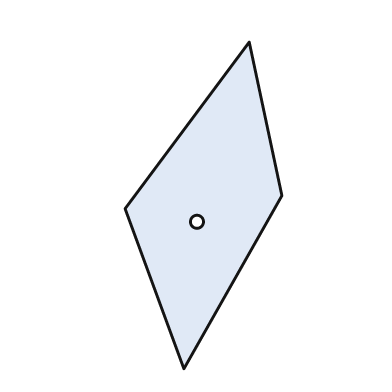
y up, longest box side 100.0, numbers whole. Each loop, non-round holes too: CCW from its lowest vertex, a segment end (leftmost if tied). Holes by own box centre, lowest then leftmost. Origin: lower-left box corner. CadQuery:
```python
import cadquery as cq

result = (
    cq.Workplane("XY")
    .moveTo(18.0, 0.0)
    .lineTo(48.0, 53.0)
    .lineTo(38.0, 100.0)
    .lineTo(0.0, 49.0)
    .close()
    .moveTo(22.0, 45.0)
    .circle(2.0)
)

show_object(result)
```